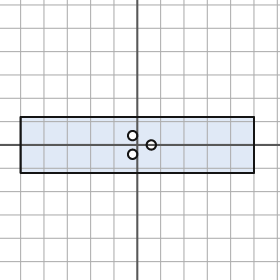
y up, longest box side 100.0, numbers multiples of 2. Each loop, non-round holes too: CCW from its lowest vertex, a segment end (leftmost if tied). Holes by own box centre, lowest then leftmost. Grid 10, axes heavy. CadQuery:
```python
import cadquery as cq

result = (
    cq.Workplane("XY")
    .moveTo(-50.0, -12.0)
    .lineTo(50.0, -12.0)
    .lineTo(50.0, 12.0)
    .lineTo(-50.0, 12.0)
    .close()
    .moveTo(-2.0, -4.0)
    .circle(2.0)
    .moveTo(6.0, 0.0)
    .circle(2.0)
    .moveTo(-2.0, 4.0)
    .circle(2.0)
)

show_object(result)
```